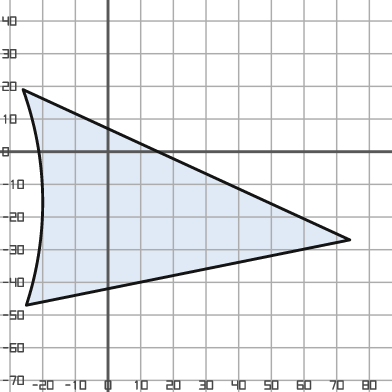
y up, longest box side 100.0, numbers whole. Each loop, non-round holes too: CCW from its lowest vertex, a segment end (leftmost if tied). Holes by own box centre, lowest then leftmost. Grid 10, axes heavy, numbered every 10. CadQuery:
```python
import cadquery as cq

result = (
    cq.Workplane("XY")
    .moveTo(-25.0, -47.0)
    .lineTo(74.0, -27.0)
    .lineTo(-26.0, 19.0)
    .threePointArc((-20.0, -14.0), (-25.0, -47.0))
    .close()
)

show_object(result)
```